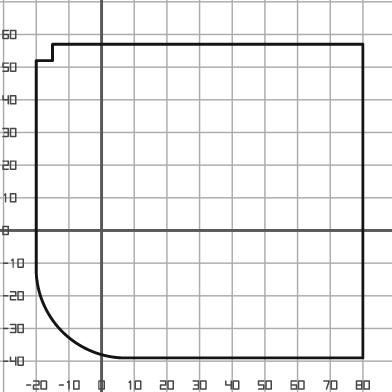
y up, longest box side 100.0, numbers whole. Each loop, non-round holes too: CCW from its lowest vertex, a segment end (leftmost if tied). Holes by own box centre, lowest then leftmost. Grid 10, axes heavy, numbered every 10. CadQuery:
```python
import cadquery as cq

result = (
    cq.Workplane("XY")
    .moveTo(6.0, -39.0)
    .lineTo(80.0, -39.0)
    .lineTo(80.0, 57.0)
    .lineTo(-15.0, 57.0)
    .lineTo(-15.0, 52.0)
    .lineTo(-20.0, 52.0)
    .lineTo(-20.0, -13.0)
    .threePointArc((-12.0, -31.0), (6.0, -39.0))
    .close()
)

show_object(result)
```